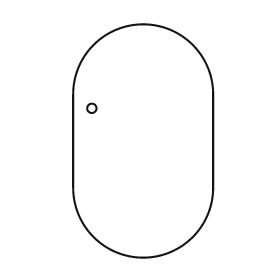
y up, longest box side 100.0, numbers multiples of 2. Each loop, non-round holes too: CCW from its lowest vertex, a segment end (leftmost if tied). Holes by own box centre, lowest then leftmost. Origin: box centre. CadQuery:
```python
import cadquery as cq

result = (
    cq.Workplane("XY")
    .moveTo(-30.0, -20.0)
    .threePointArc((0.0, -50.0), (30.0, -20.0))
    .lineTo(30.0, 20.0)
    .threePointArc((0.0, 50.0), (-30.0, 20.0))
    .close()
    .moveTo(-22.0, 14.0)
    .circle(2.0)
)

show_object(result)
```